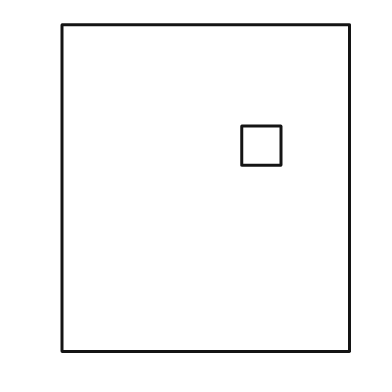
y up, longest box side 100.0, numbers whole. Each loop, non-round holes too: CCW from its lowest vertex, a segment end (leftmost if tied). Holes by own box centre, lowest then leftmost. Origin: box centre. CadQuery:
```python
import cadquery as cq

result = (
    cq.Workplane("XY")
    .moveTo(-44.0, -50.0)
    .lineTo(44.0, -50.0)
    .lineTo(44.0, 50.0)
    .lineTo(-44.0, 50.0)
    .close()
    .moveTo(11.0, 7.0)
    .lineTo(23.0, 7.0)
    .lineTo(23.0, 19.0)
    .lineTo(11.0, 19.0)
    .close()
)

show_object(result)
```